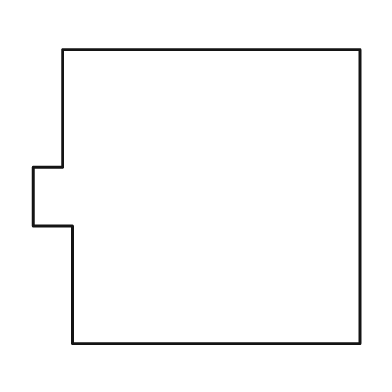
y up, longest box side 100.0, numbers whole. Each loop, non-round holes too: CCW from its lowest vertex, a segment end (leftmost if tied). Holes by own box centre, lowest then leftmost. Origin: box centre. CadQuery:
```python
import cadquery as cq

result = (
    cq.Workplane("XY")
    .moveTo(-38.0, -45.0)
    .lineTo(50.0, -45.0)
    .lineTo(50.0, 45.0)
    .lineTo(-41.0, 45.0)
    .lineTo(-41.0, 9.0)
    .lineTo(-50.0, 9.0)
    .lineTo(-50.0, -9.0)
    .lineTo(-38.0, -9.0)
    .close()
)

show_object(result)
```